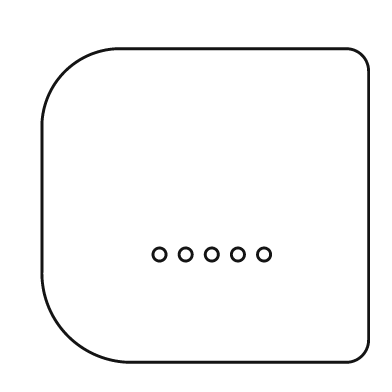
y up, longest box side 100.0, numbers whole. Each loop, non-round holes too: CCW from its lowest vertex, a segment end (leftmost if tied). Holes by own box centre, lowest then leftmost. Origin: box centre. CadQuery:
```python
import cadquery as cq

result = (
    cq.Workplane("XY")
    .moveTo(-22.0, -48.0)
    .lineTo(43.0, -48.0)
    .threePointArc((48.0, -46.0), (50.0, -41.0))
    .lineTo(50.0, 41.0)
    .threePointArc((48.0, 46.0), (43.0, 48.0))
    .lineTo(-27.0, 48.0)
    .threePointArc((-43.0, 41.0), (-50.0, 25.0))
    .lineTo(-50.0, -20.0)
    .threePointArc((-42.0, -40.0), (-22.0, -48.0))
    .close()
    .moveTo(-14.0, -15.0)
    .circle(2.0)
    .moveTo(-6.0, -15.0)
    .circle(2.0)
    .moveTo(2.0, -15.0)
    .circle(2.0)
    .moveTo(10.0, -15.0)
    .circle(2.0)
    .moveTo(18.0, -15.0)
    .circle(2.0)
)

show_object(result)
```